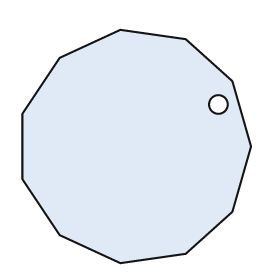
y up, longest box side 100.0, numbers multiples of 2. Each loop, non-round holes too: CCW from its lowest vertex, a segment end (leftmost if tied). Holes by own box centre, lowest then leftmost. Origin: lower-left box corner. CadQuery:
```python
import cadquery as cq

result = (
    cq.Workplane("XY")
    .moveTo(42.0, 0.0)
    .lineTo(70.0, 4.0)
    .lineTo(90.0, 22.0)
    .lineTo(98.0, 50.0)
    .lineTo(90.0, 78.0)
    .lineTo(70.0, 96.0)
    .lineTo(42.0, 100.0)
    .lineTo(16.0, 88.0)
    .lineTo(0.0, 64.0)
    .lineTo(0.0, 36.0)
    .lineTo(16.0, 12.0)
    .close()
    .moveTo(84.0, 68.0)
    .circle(4.0)
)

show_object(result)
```